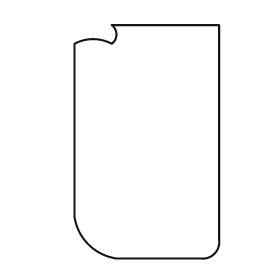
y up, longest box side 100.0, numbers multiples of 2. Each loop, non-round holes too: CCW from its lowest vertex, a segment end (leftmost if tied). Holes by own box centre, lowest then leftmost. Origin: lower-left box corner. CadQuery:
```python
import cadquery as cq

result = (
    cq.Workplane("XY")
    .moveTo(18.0, 0.0)
    .lineTo(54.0, 0.0)
    .threePointArc((60.0, 2.0), (62.0, 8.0))
    .lineTo(62.0, 100.0)
    .lineTo(16.0, 100.0)
    .threePointArc((18.0, 96.0), (16.0, 92.0))
    .threePointArc((8.0, 94.0), (0.0, 92.0))
    .lineTo(0.0, 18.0)
    .threePointArc((6.0, 6.0), (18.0, 0.0))
    .close()
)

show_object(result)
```